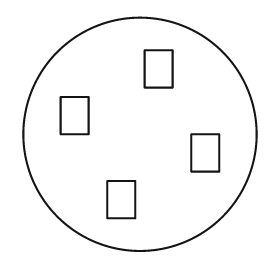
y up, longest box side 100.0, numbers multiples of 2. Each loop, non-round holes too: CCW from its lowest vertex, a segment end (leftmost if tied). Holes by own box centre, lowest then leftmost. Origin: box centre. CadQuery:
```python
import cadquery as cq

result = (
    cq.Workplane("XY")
    .moveTo(0.0, 0.0)
    .circle(50.0)
    .moveTo(-14.0, -36.0)
    .lineTo(-2.0, -36.0)
    .lineTo(-2.0, -20.0)
    .lineTo(-14.0, -20.0)
    .close()
    .moveTo(22.0, -16.0)
    .lineTo(34.0, -16.0)
    .lineTo(34.0, 0.0)
    .lineTo(22.0, 0.0)
    .close()
    .moveTo(-34.0, 0.0)
    .lineTo(-22.0, 0.0)
    .lineTo(-22.0, 16.0)
    .lineTo(-34.0, 16.0)
    .close()
    .moveTo(2.0, 20.0)
    .lineTo(14.0, 20.0)
    .lineTo(14.0, 36.0)
    .lineTo(2.0, 36.0)
    .close()
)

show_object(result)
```